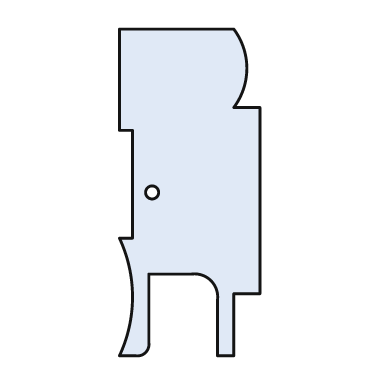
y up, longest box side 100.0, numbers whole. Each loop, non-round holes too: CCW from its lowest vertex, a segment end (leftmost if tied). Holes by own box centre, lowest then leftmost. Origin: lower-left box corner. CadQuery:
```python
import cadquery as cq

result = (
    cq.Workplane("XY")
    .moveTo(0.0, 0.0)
    .lineTo(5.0, 0.0)
    .threePointArc((8.0, 1.0), (9.0, 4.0))
    .lineTo(9.0, 25.0)
    .lineTo(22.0, 25.0)
    .threePointArc((28.0, 23.0), (30.0, 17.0))
    .lineTo(30.0, 0.0)
    .lineTo(35.0, 0.0)
    .lineTo(35.0, 19.0)
    .lineTo(43.0, 19.0)
    .lineTo(43.0, 76.0)
    .lineTo(35.0, 76.0)
    .threePointArc((39.0, 88.0), (35.0, 100.0))
    .lineTo(0.0, 100.0)
    .lineTo(0.0, 69.0)
    .lineTo(4.0, 69.0)
    .lineTo(4.0, 36.0)
    .lineTo(0.0, 36.0)
    .threePointArc((4.0, 18.0), (0.0, 0.0))
    .close()
    .moveTo(10.0, 50.0)
    .circle(2.0)
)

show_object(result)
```